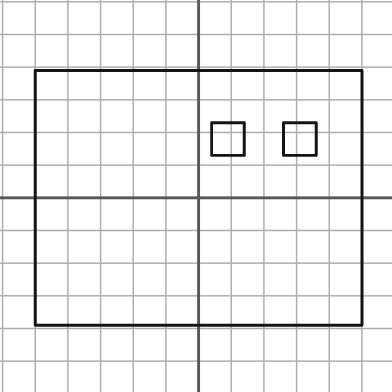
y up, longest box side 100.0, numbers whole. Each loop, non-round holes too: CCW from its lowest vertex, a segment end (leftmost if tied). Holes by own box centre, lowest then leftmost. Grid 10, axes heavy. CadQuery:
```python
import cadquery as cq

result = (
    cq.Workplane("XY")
    .moveTo(-50.0, -39.0)
    .lineTo(50.0, -39.0)
    .lineTo(50.0, 39.0)
    .lineTo(-50.0, 39.0)
    .close()
    .moveTo(4.0, 13.0)
    .lineTo(14.0, 13.0)
    .lineTo(14.0, 23.0)
    .lineTo(4.0, 23.0)
    .close()
    .moveTo(26.0, 13.0)
    .lineTo(36.0, 13.0)
    .lineTo(36.0, 23.0)
    .lineTo(26.0, 23.0)
    .close()
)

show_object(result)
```